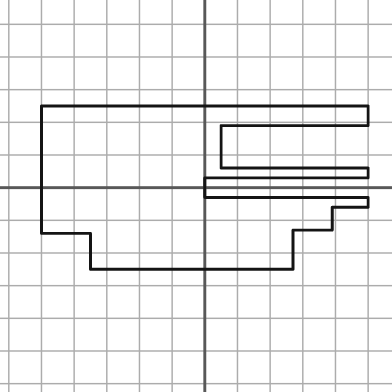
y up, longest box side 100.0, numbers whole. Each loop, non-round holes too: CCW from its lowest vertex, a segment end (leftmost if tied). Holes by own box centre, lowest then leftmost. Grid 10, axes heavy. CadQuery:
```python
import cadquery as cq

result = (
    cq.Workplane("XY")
    .moveTo(-35.0, -25.0)
    .lineTo(27.0, -25.0)
    .lineTo(27.0, -13.0)
    .lineTo(39.0, -13.0)
    .lineTo(39.0, -6.0)
    .lineTo(50.0, -6.0)
    .lineTo(50.0, -3.0)
    .lineTo(0.0, -3.0)
    .lineTo(0.0, 3.0)
    .lineTo(50.0, 3.0)
    .lineTo(50.0, 6.0)
    .lineTo(5.0, 6.0)
    .lineTo(5.0, 19.0)
    .lineTo(50.0, 19.0)
    .lineTo(50.0, 25.0)
    .lineTo(-50.0, 25.0)
    .lineTo(-50.0, -14.0)
    .lineTo(-35.0, -14.0)
    .close()
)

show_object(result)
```